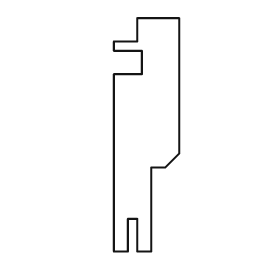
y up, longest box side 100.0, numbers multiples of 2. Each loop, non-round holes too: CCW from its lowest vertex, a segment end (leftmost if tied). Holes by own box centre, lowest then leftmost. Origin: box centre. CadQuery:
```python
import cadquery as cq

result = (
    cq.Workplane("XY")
    .moveTo(-14.0, -50.0)
    .lineTo(-8.0, -50.0)
    .lineTo(-8.0, -36.0)
    .lineTo(-4.0, -36.0)
    .lineTo(-4.0, -50.0)
    .lineTo(2.0, -50.0)
    .lineTo(2.0, -14.0)
    .lineTo(8.0, -14.0)
    .lineTo(14.0, -8.0)
    .lineTo(14.0, 50.0)
    .lineTo(-4.0, 50.0)
    .lineTo(-4.0, 40.0)
    .lineTo(-14.0, 40.0)
    .lineTo(-14.0, 36.0)
    .lineTo(-2.0, 36.0)
    .lineTo(-2.0, 26.0)
    .lineTo(-14.0, 26.0)
    .close()
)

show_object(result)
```